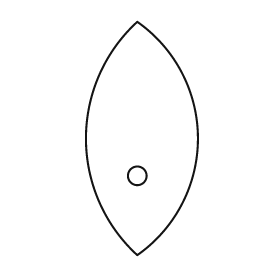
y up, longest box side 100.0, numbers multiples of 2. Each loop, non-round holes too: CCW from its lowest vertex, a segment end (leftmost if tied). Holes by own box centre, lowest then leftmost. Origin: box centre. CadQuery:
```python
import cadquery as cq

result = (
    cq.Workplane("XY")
    .moveTo(-2.0, -50.0)
    .threePointArc((24.0, 0.0), (-2.0, 50.0))
    .threePointArc((-24.0, 0.0), (-2.0, -50.0))
    .close()
    .moveTo(-2.0, -16.0)
    .circle(4.0)
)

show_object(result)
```